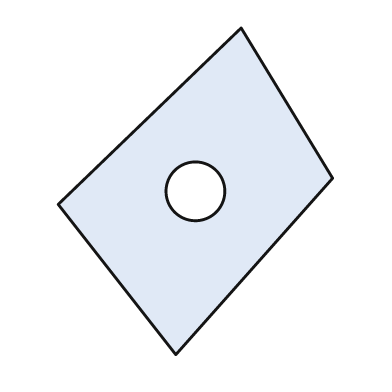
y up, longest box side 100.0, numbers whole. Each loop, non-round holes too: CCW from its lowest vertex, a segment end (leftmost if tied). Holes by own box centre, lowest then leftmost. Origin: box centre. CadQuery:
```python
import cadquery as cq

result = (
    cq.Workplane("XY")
    .moveTo(-6.0, -50.0)
    .lineTo(42.0, 4.0)
    .lineTo(14.0, 50.0)
    .lineTo(-42.0, -4.0)
    .close()
    .moveTo(0.0, 0.0)
    .circle(9.0)
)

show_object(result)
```